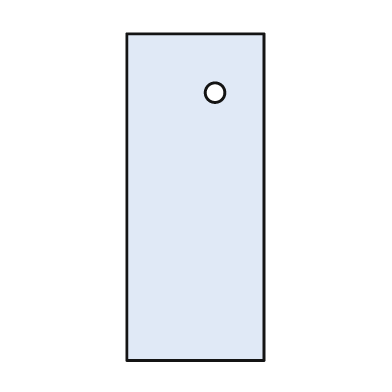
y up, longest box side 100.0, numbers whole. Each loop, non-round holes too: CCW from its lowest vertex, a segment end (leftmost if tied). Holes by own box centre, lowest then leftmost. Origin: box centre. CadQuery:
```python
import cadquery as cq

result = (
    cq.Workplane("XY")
    .moveTo(-21.0, -50.0)
    .lineTo(21.0, -50.0)
    .lineTo(21.0, 50.0)
    .lineTo(-21.0, 50.0)
    .close()
    .moveTo(6.0, 32.0)
    .circle(3.0)
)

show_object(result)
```